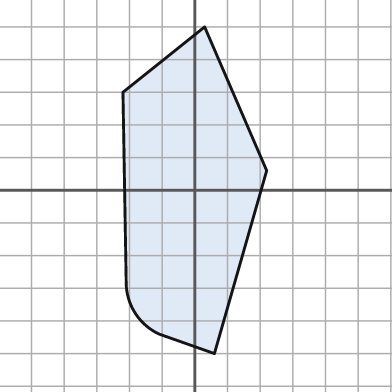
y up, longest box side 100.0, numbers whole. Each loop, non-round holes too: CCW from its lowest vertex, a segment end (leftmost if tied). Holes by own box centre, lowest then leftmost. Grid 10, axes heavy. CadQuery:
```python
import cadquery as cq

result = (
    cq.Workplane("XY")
    .moveTo(6.0, -50.0)
    .lineTo(22.0, 6.0)
    .lineTo(3.0, 50.0)
    .lineTo(-22.0, 30.0)
    .lineTo(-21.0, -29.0)
    .threePointArc((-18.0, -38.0), (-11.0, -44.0))
    .close()
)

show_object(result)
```